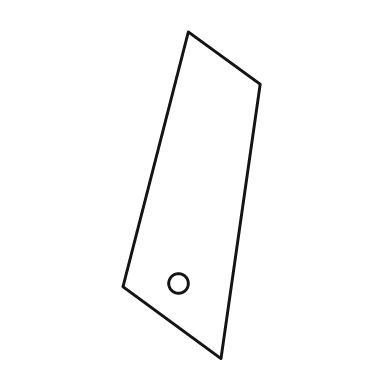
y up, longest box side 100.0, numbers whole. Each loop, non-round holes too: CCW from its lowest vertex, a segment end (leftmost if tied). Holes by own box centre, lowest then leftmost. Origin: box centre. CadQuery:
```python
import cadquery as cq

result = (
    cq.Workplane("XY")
    .moveTo(9.0, -50.0)
    .lineTo(21.0, 34.0)
    .lineTo(-1.0, 50.0)
    .lineTo(-21.0, -28.0)
    .close()
    .moveTo(-4.0, -27.0)
    .circle(3.0)
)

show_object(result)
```